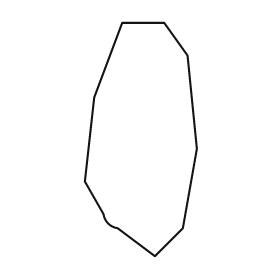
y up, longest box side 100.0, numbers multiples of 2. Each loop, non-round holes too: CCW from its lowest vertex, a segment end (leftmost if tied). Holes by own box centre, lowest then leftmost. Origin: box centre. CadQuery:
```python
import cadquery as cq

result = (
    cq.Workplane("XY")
    .moveTo(6.0, -50.0)
    .lineTo(18.0, -38.0)
    .lineTo(24.0, -4.0)
    .lineTo(20.0, 36.0)
    .lineTo(10.0, 50.0)
    .lineTo(-8.0, 50.0)
    .lineTo(-20.0, 18.0)
    .lineTo(-24.0, -18.0)
    .lineTo(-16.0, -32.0)
    .threePointArc((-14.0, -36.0), (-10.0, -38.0))
    .close()
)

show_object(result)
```